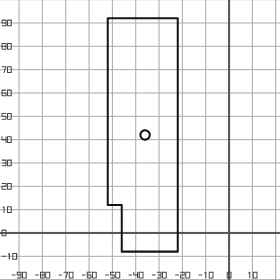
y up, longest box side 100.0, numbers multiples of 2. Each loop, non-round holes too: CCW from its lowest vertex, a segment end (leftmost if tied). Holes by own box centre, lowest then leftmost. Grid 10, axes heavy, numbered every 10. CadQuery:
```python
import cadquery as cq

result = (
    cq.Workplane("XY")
    .moveTo(-46.0, -8.0)
    .lineTo(-22.0, -8.0)
    .lineTo(-22.0, 92.0)
    .lineTo(-52.0, 92.0)
    .lineTo(-52.0, 12.0)
    .lineTo(-46.0, 12.0)
    .close()
    .moveTo(-36.0, 42.0)
    .circle(2.0)
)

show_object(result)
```